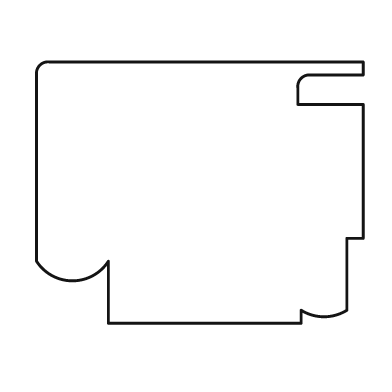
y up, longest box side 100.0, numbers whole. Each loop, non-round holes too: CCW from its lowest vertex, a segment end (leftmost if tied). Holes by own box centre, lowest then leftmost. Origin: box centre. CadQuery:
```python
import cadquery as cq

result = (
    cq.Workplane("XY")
    .moveTo(-28.0, -40.0)
    .lineTo(31.0, -40.0)
    .lineTo(31.0, -36.0)
    .threePointArc((38.0, -38.0), (45.0, -36.0))
    .lineTo(45.0, -14.0)
    .lineTo(50.0, -14.0)
    .lineTo(50.0, 27.0)
    .lineTo(30.0, 27.0)
    .lineTo(30.0, 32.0)
    .threePointArc((31.0, 35.0), (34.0, 36.0))
    .lineTo(50.0, 36.0)
    .lineTo(50.0, 40.0)
    .lineTo(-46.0, 40.0)
    .threePointArc((-49.0, 39.0), (-50.0, 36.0))
    .lineTo(-50.0, -21.0)
    .threePointArc((-39.0, -27.0), (-28.0, -21.0))
    .close()
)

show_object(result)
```